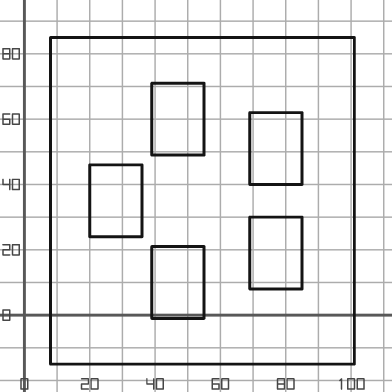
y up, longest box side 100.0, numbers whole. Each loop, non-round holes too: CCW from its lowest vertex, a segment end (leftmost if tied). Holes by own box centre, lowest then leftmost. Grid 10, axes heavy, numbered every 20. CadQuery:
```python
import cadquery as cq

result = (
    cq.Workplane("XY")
    .moveTo(8.0, -15.0)
    .lineTo(101.0, -15.0)
    .lineTo(101.0, 85.0)
    .lineTo(8.0, 85.0)
    .close()
    .moveTo(39.0, -1.0)
    .lineTo(55.0, -1.0)
    .lineTo(55.0, 21.0)
    .lineTo(39.0, 21.0)
    .close()
    .moveTo(69.0, 8.0)
    .lineTo(85.0, 8.0)
    .lineTo(85.0, 30.0)
    .lineTo(69.0, 30.0)
    .close()
    .moveTo(20.0, 24.0)
    .lineTo(36.0, 24.0)
    .lineTo(36.0, 46.0)
    .lineTo(20.0, 46.0)
    .close()
    .moveTo(69.0, 40.0)
    .lineTo(85.0, 40.0)
    .lineTo(85.0, 62.0)
    .lineTo(69.0, 62.0)
    .close()
    .moveTo(39.0, 49.0)
    .lineTo(55.0, 49.0)
    .lineTo(55.0, 71.0)
    .lineTo(39.0, 71.0)
    .close()
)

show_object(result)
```